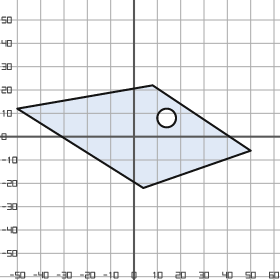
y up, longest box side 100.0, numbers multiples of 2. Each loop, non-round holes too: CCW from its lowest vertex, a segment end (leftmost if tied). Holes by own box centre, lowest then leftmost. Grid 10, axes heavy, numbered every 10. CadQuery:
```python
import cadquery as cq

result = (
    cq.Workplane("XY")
    .moveTo(4.0, -22.0)
    .lineTo(50.0, -6.0)
    .lineTo(8.0, 22.0)
    .lineTo(-50.0, 12.0)
    .close()
    .moveTo(14.0, 8.0)
    .circle(4.0)
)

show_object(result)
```